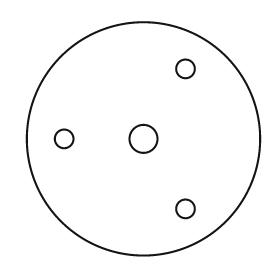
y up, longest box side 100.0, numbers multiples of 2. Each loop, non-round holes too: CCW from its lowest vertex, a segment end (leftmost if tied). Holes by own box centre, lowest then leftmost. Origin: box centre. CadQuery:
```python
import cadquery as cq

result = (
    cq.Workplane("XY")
    .moveTo(0.0, 0.0)
    .circle(50.0)
    .moveTo(18.0, -30.0)
    .circle(4.0)
    .moveTo(-34.0, 0.0)
    .circle(4.0)
    .moveTo(0.0, 0.0)
    .circle(6.0)
    .moveTo(18.0, 30.0)
    .circle(4.0)
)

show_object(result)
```